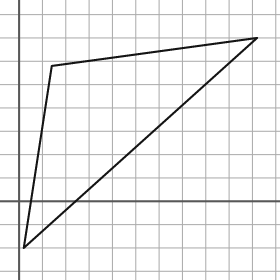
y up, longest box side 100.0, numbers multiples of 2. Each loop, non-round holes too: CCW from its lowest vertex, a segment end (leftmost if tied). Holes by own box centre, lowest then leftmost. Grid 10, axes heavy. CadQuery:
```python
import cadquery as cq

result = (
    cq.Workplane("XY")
    .moveTo(2.0, -20.0)
    .lineTo(102.0, 70.0)
    .lineTo(14.0, 58.0)
    .close()
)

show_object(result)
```